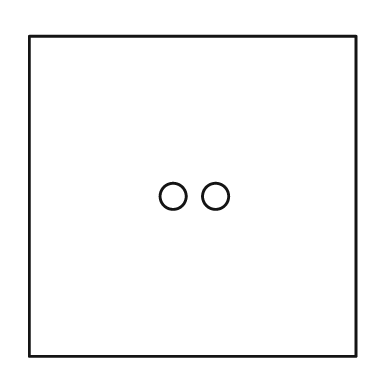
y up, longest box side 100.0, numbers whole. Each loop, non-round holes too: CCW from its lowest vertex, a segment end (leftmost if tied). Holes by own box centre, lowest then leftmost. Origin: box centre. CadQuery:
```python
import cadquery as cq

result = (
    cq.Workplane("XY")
    .moveTo(-50.0, -49.0)
    .lineTo(50.0, -49.0)
    .lineTo(50.0, 49.0)
    .lineTo(-50.0, 49.0)
    .close()
    .moveTo(-6.0, 0.0)
    .circle(4.0)
    .moveTo(7.0, 0.0)
    .circle(4.0)
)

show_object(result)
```